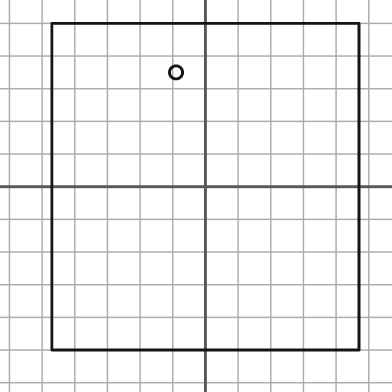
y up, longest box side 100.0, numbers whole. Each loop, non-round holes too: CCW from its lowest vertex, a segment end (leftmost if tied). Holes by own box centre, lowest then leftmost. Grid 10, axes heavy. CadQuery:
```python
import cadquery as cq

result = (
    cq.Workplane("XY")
    .moveTo(-47.0, -50.0)
    .lineTo(47.0, -50.0)
    .lineTo(47.0, 50.0)
    .lineTo(-47.0, 50.0)
    .close()
    .moveTo(-9.0, 35.0)
    .circle(2.0)
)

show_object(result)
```